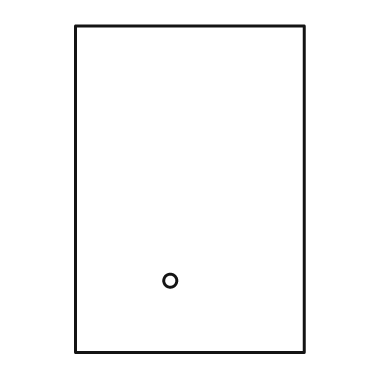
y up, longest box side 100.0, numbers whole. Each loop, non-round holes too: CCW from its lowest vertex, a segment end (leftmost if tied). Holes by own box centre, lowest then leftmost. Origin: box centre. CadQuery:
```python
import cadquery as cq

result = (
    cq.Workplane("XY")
    .moveTo(-35.0, -50.0)
    .lineTo(35.0, -50.0)
    .lineTo(35.0, 50.0)
    .lineTo(-35.0, 50.0)
    .close()
    .moveTo(-6.0, -28.0)
    .circle(2.0)
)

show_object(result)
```